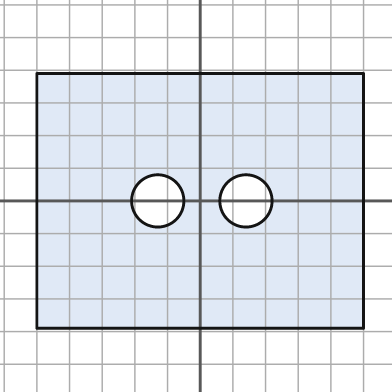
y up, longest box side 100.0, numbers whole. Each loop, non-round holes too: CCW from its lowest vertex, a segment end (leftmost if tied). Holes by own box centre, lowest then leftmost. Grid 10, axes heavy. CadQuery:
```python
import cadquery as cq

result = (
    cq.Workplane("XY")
    .moveTo(-50.0, -39.0)
    .lineTo(50.0, -39.0)
    .lineTo(50.0, 39.0)
    .lineTo(-50.0, 39.0)
    .close()
    .moveTo(-13.0, 0.0)
    .circle(8.0)
    .moveTo(14.0, 0.0)
    .circle(8.0)
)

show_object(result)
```